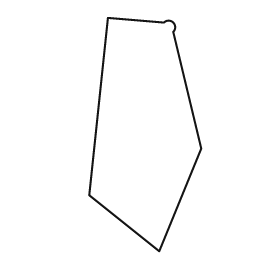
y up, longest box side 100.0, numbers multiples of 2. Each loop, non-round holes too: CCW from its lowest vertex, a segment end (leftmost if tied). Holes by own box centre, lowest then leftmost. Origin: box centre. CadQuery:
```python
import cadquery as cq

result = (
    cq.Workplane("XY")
    .moveTo(6.0, -50.0)
    .lineTo(24.0, -6.0)
    .lineTo(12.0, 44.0)
    .threePointArc((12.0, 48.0), (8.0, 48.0))
    .lineTo(-16.0, 50.0)
    .lineTo(-24.0, -26.0)
    .close()
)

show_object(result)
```